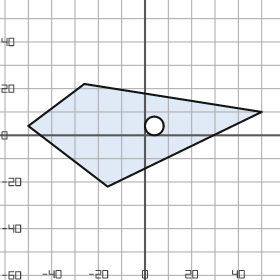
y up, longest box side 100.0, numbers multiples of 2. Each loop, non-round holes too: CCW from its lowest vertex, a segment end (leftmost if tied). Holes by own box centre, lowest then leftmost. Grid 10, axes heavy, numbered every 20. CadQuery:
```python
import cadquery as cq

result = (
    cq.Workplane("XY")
    .moveTo(-16.0, -22.0)
    .lineTo(50.0, 10.0)
    .lineTo(-26.0, 22.0)
    .lineTo(-50.0, 4.0)
    .close()
    .moveTo(4.0, 4.0)
    .circle(4.0)
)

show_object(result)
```